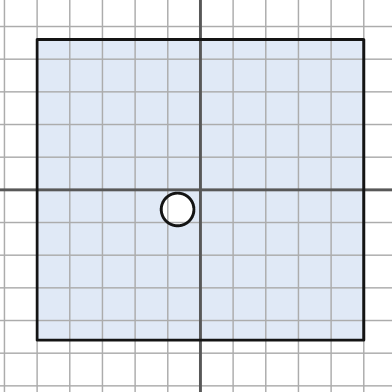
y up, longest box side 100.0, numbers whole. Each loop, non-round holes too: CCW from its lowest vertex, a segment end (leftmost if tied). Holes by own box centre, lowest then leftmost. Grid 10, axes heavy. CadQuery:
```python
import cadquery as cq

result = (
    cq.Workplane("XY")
    .moveTo(-50.0, -46.0)
    .lineTo(50.0, -46.0)
    .lineTo(50.0, 46.0)
    .lineTo(-50.0, 46.0)
    .close()
    .moveTo(-7.0, -6.0)
    .circle(5.0)
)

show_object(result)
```